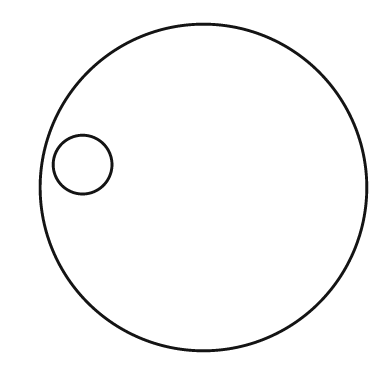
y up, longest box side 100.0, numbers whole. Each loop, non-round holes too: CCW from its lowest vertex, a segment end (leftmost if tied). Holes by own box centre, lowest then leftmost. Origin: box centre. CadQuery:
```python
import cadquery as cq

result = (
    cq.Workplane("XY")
    .moveTo(0.0, 0.0)
    .circle(50.0)
    .moveTo(-37.0, 7.0)
    .circle(9.0)
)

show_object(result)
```